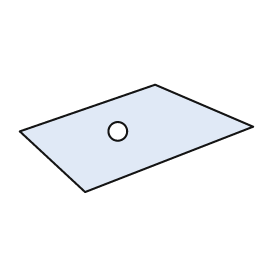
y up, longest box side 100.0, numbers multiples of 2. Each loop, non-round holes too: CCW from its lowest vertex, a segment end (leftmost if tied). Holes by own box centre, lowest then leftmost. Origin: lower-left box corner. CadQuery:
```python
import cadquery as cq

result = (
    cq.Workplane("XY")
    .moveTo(28.0, 0.0)
    .lineTo(100.0, 28.0)
    .lineTo(58.0, 46.0)
    .lineTo(0.0, 26.0)
    .close()
    .moveTo(42.0, 26.0)
    .circle(4.0)
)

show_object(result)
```